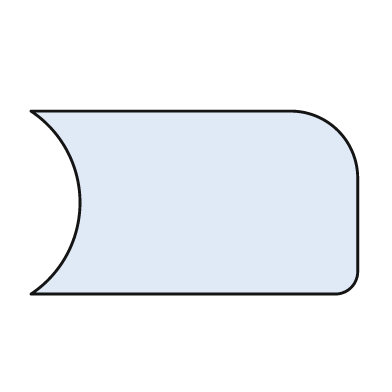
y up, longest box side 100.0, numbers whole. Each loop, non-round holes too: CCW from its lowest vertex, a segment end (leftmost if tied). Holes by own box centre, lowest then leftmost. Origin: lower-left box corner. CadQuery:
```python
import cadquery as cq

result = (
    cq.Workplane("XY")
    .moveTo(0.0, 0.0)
    .lineTo(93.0, 0.0)
    .threePointArc((98.0, 2.0), (100.0, 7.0))
    .lineTo(100.0, 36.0)
    .threePointArc((94.0, 50.0), (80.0, 56.0))
    .lineTo(0.0, 56.0)
    .threePointArc((15.0, 28.0), (0.0, 0.0))
    .close()
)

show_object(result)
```